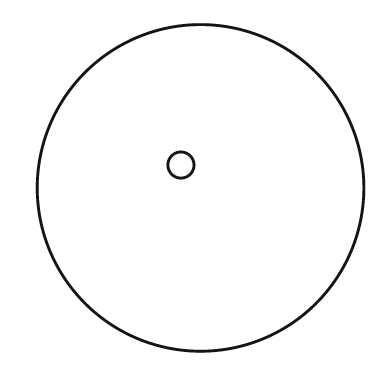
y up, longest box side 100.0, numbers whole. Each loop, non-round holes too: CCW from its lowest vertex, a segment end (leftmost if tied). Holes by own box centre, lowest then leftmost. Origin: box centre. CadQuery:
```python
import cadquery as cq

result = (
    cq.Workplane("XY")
    .moveTo(0.0, 0.0)
    .circle(50.0)
    .moveTo(-6.0, 7.0)
    .circle(4.0)
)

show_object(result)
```